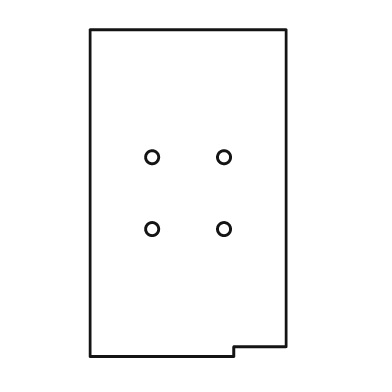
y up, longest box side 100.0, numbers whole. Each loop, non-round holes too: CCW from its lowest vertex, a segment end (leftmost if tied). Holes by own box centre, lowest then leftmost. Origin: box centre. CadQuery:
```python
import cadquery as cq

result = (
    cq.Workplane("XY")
    .moveTo(-30.0, -50.0)
    .lineTo(14.0, -50.0)
    .lineTo(14.0, -47.0)
    .lineTo(30.0, -47.0)
    .lineTo(30.0, 50.0)
    .lineTo(-30.0, 50.0)
    .close()
    .moveTo(-11.0, -11.0)
    .circle(2.0)
    .moveTo(11.0, -11.0)
    .circle(2.0)
    .moveTo(-11.0, 11.0)
    .circle(2.0)
    .moveTo(11.0, 11.0)
    .circle(2.0)
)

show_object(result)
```